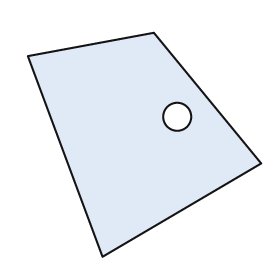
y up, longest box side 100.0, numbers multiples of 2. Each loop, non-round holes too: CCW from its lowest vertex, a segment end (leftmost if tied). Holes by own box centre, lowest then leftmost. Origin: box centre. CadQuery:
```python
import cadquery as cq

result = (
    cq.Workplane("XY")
    .moveTo(-18.0, -48.0)
    .lineTo(50.0, -8.0)
    .lineTo(4.0, 48.0)
    .lineTo(-50.0, 38.0)
    .close()
    .moveTo(14.0, 12.0)
    .circle(6.0)
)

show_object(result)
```